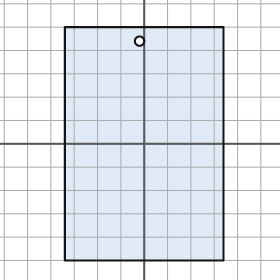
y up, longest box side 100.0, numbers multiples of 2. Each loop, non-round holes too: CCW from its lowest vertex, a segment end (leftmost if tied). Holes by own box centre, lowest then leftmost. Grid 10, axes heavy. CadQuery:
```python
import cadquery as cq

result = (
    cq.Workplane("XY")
    .moveTo(-34.0, -50.0)
    .lineTo(34.0, -50.0)
    .lineTo(34.0, 50.0)
    .lineTo(-34.0, 50.0)
    .close()
    .moveTo(-2.0, 44.0)
    .circle(2.0)
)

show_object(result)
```